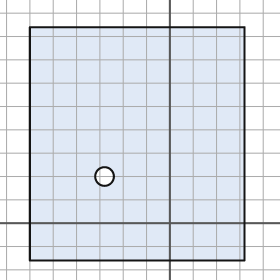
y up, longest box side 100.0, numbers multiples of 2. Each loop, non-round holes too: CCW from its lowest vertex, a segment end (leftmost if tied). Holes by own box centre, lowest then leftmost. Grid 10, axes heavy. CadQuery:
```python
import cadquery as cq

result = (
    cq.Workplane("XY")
    .moveTo(-60.0, -16.0)
    .lineTo(32.0, -16.0)
    .lineTo(32.0, 84.0)
    .lineTo(-60.0, 84.0)
    .close()
    .moveTo(-28.0, 20.0)
    .circle(4.0)
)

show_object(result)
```